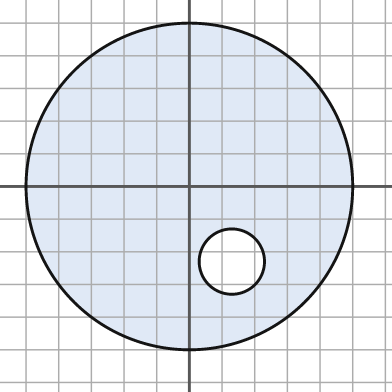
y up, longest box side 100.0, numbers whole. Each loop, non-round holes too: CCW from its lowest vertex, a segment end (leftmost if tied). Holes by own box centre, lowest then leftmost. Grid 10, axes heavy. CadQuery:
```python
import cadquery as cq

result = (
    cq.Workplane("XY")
    .moveTo(0.0, 0.0)
    .circle(50.0)
    .moveTo(13.0, -23.0)
    .circle(10.0)
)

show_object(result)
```